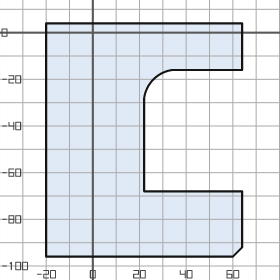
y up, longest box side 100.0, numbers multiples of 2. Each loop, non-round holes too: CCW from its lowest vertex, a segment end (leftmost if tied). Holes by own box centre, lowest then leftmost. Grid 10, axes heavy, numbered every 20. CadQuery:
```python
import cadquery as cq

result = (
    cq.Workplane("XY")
    .moveTo(-20.0, -96.0)
    .lineTo(60.0, -96.0)
    .lineTo(64.0, -92.0)
    .lineTo(64.0, -68.0)
    .lineTo(22.0, -68.0)
    .lineTo(22.0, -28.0)
    .threePointArc((26.0, -20.0), (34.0, -16.0))
    .lineTo(64.0, -16.0)
    .lineTo(64.0, 4.0)
    .lineTo(-20.0, 4.0)
    .close()
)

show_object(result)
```